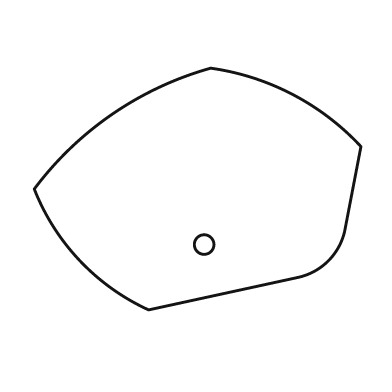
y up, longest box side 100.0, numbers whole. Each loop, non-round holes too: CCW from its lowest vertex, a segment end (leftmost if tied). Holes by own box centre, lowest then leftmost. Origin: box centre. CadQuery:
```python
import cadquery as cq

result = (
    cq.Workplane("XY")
    .moveTo(-15.0, -37.0)
    .lineTo(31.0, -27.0)
    .threePointArc((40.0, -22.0), (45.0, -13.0))
    .lineTo(50.0, 13.0)
    .threePointArc((29.0, 29.0), (4.0, 37.0))
    .threePointArc((-26.0, 23.0), (-50.0, 0.0))
    .threePointArc((-36.0, -22.0), (-15.0, -37.0))
    .close()
    .moveTo(2.0, -17.0)
    .circle(3.0)
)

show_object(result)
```